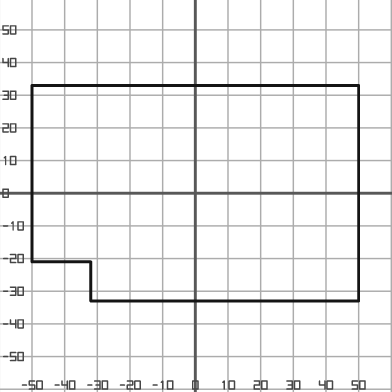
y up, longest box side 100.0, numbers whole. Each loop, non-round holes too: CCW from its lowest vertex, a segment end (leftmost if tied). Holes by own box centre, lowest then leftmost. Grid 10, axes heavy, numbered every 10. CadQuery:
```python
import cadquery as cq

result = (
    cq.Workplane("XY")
    .moveTo(-32.0, -33.0)
    .lineTo(50.0, -33.0)
    .lineTo(50.0, 33.0)
    .lineTo(-50.0, 33.0)
    .lineTo(-50.0, -21.0)
    .lineTo(-32.0, -21.0)
    .close()
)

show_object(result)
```